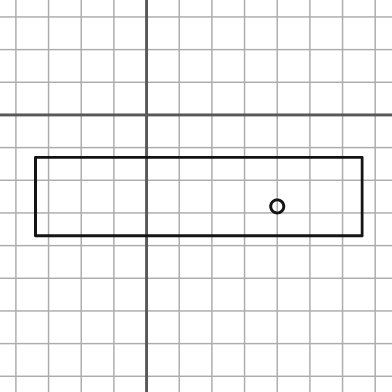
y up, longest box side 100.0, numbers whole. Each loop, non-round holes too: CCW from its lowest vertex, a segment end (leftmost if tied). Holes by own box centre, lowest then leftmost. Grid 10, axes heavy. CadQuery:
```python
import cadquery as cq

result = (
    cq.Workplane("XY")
    .moveTo(-34.0, -37.0)
    .lineTo(66.0, -37.0)
    .lineTo(66.0, -13.0)
    .lineTo(-34.0, -13.0)
    .close()
    .moveTo(40.0, -28.0)
    .circle(2.0)
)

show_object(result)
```